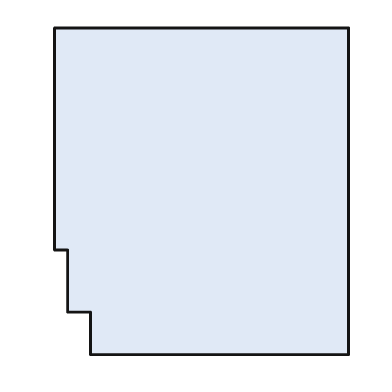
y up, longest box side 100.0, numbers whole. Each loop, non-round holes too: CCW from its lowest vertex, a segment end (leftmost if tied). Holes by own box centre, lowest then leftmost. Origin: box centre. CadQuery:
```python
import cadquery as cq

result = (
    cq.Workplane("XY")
    .moveTo(-34.0, -50.0)
    .lineTo(45.0, -50.0)
    .lineTo(45.0, 50.0)
    .lineTo(-45.0, 50.0)
    .lineTo(-45.0, -18.0)
    .lineTo(-41.0, -18.0)
    .lineTo(-41.0, -37.0)
    .lineTo(-34.0, -37.0)
    .close()
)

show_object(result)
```